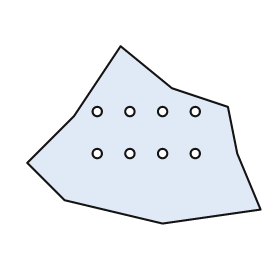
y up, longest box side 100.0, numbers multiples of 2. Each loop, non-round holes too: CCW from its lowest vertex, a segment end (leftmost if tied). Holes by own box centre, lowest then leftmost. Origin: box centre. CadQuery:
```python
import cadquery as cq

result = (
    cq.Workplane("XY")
    .moveTo(8.0, -38.0)
    .lineTo(50.0, -32.0)
    .lineTo(40.0, -8.0)
    .lineTo(36.0, 12.0)
    .lineTo(12.0, 20.0)
    .lineTo(-10.0, 38.0)
    .lineTo(-30.0, 8.0)
    .lineTo(-50.0, -12.0)
    .lineTo(-34.0, -28.0)
    .close()
    .moveTo(-20.0, -8.0)
    .circle(2.0)
    .moveTo(-6.0, -8.0)
    .circle(2.0)
    .moveTo(8.0, -8.0)
    .circle(2.0)
    .moveTo(22.0, -8.0)
    .circle(2.0)
    .moveTo(-20.0, 10.0)
    .circle(2.0)
    .moveTo(-6.0, 10.0)
    .circle(2.0)
    .moveTo(8.0, 10.0)
    .circle(2.0)
    .moveTo(22.0, 10.0)
    .circle(2.0)
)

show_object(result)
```